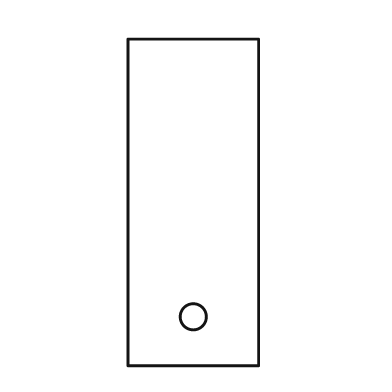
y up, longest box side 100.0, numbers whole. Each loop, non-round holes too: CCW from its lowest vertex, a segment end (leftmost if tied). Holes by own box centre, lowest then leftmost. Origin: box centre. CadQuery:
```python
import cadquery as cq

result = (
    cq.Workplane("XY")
    .moveTo(-20.0, -50.0)
    .lineTo(20.0, -50.0)
    .lineTo(20.0, 50.0)
    .lineTo(-20.0, 50.0)
    .close()
    .moveTo(0.0, -35.0)
    .circle(4.0)
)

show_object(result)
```